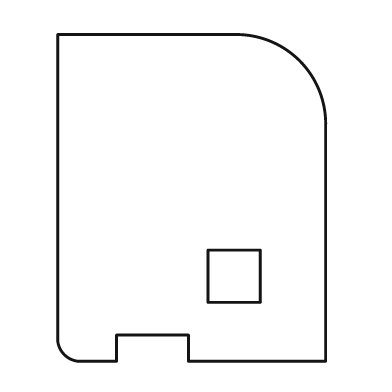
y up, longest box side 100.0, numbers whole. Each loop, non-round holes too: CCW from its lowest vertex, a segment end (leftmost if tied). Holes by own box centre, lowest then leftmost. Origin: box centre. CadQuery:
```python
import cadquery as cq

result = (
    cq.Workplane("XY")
    .moveTo(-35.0, -50.0)
    .lineTo(-23.0, -50.0)
    .lineTo(-23.0, -42.0)
    .lineTo(-1.0, -42.0)
    .lineTo(-1.0, -50.0)
    .lineTo(41.0, -50.0)
    .lineTo(41.0, 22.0)
    .threePointArc((33.0, 42.0), (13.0, 50.0))
    .lineTo(-41.0, 50.0)
    .lineTo(-41.0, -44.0)
    .threePointArc((-39.0, -48.0), (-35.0, -50.0))
    .close()
    .moveTo(5.0, -32.0)
    .lineTo(21.0, -32.0)
    .lineTo(21.0, -16.0)
    .lineTo(5.0, -16.0)
    .close()
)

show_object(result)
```